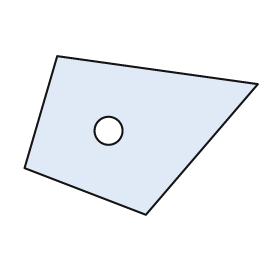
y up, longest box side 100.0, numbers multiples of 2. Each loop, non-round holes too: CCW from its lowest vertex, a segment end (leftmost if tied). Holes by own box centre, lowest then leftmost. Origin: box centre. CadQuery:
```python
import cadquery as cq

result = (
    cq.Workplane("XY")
    .moveTo(2.0, -34.0)
    .lineTo(50.0, 22.0)
    .lineTo(-36.0, 34.0)
    .lineTo(-50.0, -14.0)
    .close()
    .moveTo(-14.0, 2.0)
    .circle(6.0)
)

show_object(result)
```